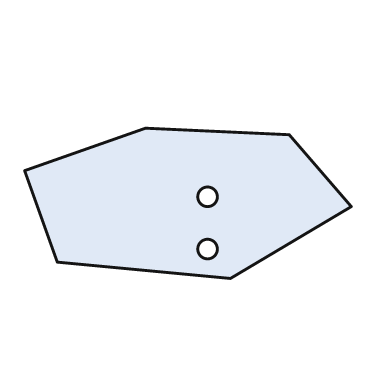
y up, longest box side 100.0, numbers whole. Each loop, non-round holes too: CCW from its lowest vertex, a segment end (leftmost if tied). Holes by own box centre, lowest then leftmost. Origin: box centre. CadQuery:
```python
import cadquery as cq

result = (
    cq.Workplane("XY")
    .moveTo(13.0, -23.0)
    .lineTo(50.0, -1.0)
    .lineTo(31.0, 21.0)
    .lineTo(-13.0, 23.0)
    .lineTo(-50.0, 10.0)
    .lineTo(-40.0, -18.0)
    .close()
    .moveTo(6.0, -14.0)
    .circle(3.0)
    .moveTo(6.0, 2.0)
    .circle(3.0)
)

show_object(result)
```